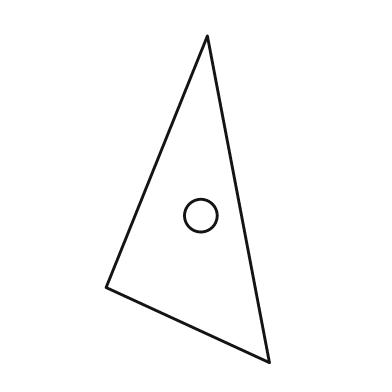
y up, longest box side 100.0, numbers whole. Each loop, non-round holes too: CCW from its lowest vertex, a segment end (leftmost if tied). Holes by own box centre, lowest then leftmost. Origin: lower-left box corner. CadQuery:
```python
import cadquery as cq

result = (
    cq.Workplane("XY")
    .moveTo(50.0, 0.0)
    .lineTo(31.0, 100.0)
    .lineTo(0.0, 23.0)
    .close()
    .moveTo(29.0, 45.0)
    .circle(5.0)
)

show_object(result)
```